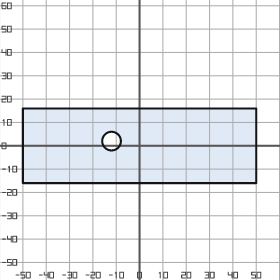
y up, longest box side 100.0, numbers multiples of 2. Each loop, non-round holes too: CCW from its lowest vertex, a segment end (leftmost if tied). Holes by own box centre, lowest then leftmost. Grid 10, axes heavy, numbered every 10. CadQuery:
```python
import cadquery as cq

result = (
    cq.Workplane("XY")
    .moveTo(-50.0, -16.0)
    .lineTo(50.0, -16.0)
    .lineTo(50.0, 16.0)
    .lineTo(-50.0, 16.0)
    .close()
    .moveTo(-12.0, 2.0)
    .circle(4.0)
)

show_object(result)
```